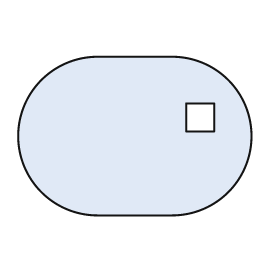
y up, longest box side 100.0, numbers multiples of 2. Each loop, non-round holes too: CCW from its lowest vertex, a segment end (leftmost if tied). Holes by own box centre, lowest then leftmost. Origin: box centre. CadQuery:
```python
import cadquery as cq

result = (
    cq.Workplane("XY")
    .moveTo(-16.0, -34.0)
    .lineTo(16.0, -34.0)
    .threePointArc((50.0, 0.0), (16.0, 34.0))
    .lineTo(-16.0, 34.0)
    .threePointArc((-50.0, 0.0), (-16.0, -34.0))
    .close()
    .moveTo(22.0, 2.0)
    .lineTo(34.0, 2.0)
    .lineTo(34.0, 14.0)
    .lineTo(22.0, 14.0)
    .close()
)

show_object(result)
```